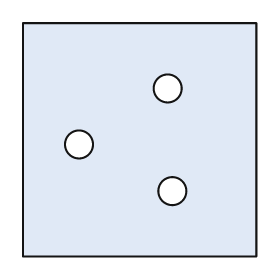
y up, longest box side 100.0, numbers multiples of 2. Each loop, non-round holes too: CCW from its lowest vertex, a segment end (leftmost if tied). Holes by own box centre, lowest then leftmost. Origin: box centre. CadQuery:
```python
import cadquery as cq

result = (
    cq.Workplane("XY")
    .moveTo(-50.0, -50.0)
    .lineTo(50.0, -50.0)
    .lineTo(50.0, 50.0)
    .lineTo(-50.0, 50.0)
    .close()
    .moveTo(14.0, -22.0)
    .circle(6.0)
    .moveTo(-26.0, -2.0)
    .circle(6.0)
    .moveTo(12.0, 22.0)
    .circle(6.0)
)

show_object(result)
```